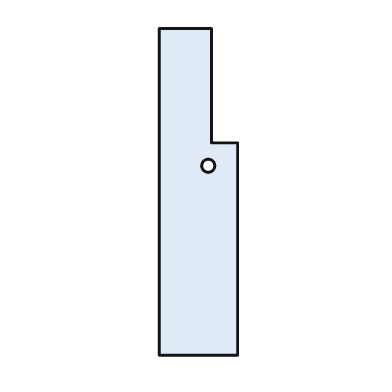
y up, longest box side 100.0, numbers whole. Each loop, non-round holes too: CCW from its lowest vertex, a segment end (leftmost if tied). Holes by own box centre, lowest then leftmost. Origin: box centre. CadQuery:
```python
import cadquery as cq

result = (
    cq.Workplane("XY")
    .moveTo(-12.0, -50.0)
    .lineTo(12.0, -50.0)
    .lineTo(12.0, 15.0)
    .lineTo(4.0, 15.0)
    .lineTo(4.0, 50.0)
    .lineTo(-12.0, 50.0)
    .close()
    .moveTo(3.0, 8.0)
    .circle(2.0)
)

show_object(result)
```